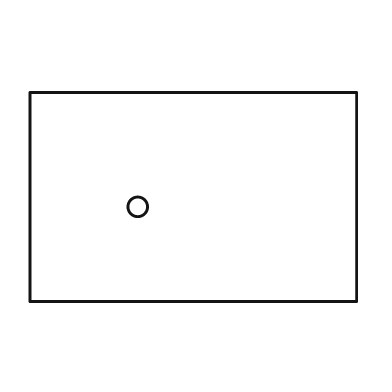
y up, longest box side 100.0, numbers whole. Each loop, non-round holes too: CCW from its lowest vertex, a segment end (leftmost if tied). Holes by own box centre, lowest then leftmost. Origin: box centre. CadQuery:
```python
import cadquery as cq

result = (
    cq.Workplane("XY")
    .moveTo(-50.0, -32.0)
    .lineTo(50.0, -32.0)
    .lineTo(50.0, 32.0)
    .lineTo(-50.0, 32.0)
    .close()
    .moveTo(-17.0, -3.0)
    .circle(3.0)
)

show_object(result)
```